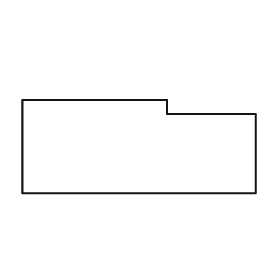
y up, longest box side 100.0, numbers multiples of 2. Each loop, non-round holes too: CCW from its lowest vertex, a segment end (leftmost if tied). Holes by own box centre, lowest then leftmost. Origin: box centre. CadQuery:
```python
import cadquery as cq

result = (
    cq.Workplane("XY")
    .moveTo(-50.0, -20.0)
    .lineTo(50.0, -20.0)
    .lineTo(50.0, 14.0)
    .lineTo(12.0, 14.0)
    .lineTo(12.0, 20.0)
    .lineTo(-50.0, 20.0)
    .close()
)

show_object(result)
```